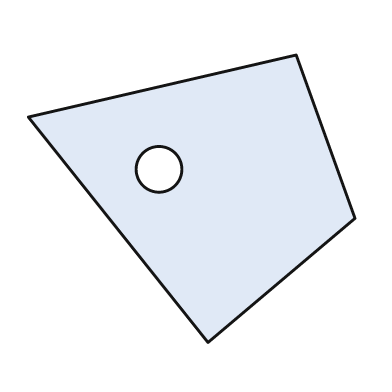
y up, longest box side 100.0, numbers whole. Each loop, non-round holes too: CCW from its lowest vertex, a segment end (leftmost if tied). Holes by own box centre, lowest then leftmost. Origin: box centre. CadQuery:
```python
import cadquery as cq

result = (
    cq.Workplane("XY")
    .moveTo(5.0, -44.0)
    .lineTo(50.0, -6.0)
    .lineTo(32.0, 44.0)
    .lineTo(-50.0, 25.0)
    .close()
    .moveTo(-10.0, 9.0)
    .circle(7.0)
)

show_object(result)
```